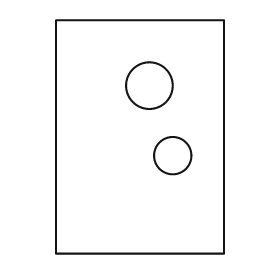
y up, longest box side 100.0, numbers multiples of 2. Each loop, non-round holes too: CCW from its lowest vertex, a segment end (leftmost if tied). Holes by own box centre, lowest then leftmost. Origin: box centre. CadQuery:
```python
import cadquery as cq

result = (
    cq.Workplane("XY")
    .moveTo(-36.0, -50.0)
    .lineTo(36.0, -50.0)
    .lineTo(36.0, 50.0)
    .lineTo(-36.0, 50.0)
    .close()
    .moveTo(14.0, -8.0)
    .circle(8.0)
    .moveTo(4.0, 22.0)
    .circle(10.0)
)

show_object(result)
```